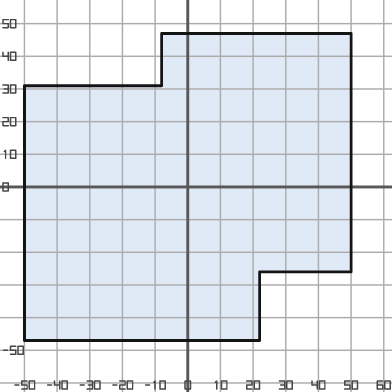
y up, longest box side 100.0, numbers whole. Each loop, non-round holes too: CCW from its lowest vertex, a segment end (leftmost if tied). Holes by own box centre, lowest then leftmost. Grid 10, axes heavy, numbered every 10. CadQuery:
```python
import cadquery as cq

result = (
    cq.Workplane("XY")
    .moveTo(-50.0, -47.0)
    .lineTo(22.0, -47.0)
    .lineTo(22.0, -26.0)
    .lineTo(50.0, -26.0)
    .lineTo(50.0, 47.0)
    .lineTo(-8.0, 47.0)
    .lineTo(-8.0, 31.0)
    .lineTo(-50.0, 31.0)
    .close()
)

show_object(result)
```